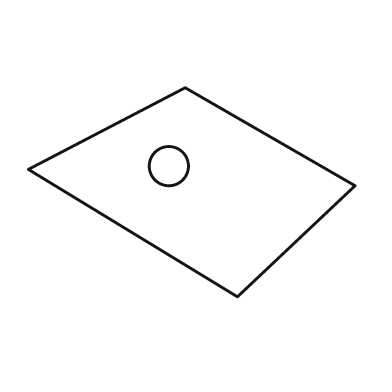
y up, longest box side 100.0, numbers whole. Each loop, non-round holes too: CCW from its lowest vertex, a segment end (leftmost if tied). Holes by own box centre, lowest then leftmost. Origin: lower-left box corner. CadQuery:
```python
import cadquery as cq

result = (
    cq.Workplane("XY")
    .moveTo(64.0, 0.0)
    .lineTo(100.0, 34.0)
    .lineTo(48.0, 64.0)
    .lineTo(0.0, 39.0)
    .close()
    .moveTo(43.0, 40.0)
    .circle(6.0)
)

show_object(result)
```